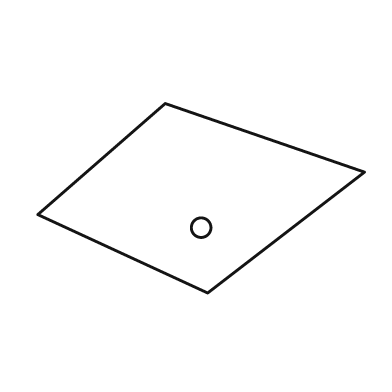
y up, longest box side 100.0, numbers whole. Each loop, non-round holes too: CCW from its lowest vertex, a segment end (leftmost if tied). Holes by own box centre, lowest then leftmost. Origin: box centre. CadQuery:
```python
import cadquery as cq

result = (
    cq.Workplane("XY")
    .moveTo(2.0, -29.0)
    .lineTo(50.0, 8.0)
    .lineTo(-11.0, 29.0)
    .lineTo(-50.0, -5.0)
    .close()
    .moveTo(0.0, -9.0)
    .circle(3.0)
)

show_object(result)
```